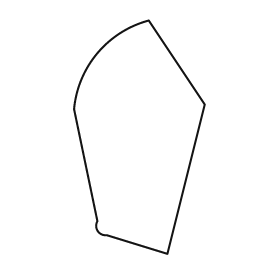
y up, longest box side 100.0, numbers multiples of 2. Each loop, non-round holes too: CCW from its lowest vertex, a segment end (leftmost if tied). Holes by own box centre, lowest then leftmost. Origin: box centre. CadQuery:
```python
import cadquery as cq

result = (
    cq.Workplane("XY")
    .moveTo(12.0, -50.0)
    .lineTo(28.0, 14.0)
    .lineTo(4.0, 50.0)
    .threePointArc((-18.0, 36.0), (-28.0, 12.0))
    .lineTo(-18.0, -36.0)
    .threePointArc((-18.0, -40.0), (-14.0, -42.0))
    .close()
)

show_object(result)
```